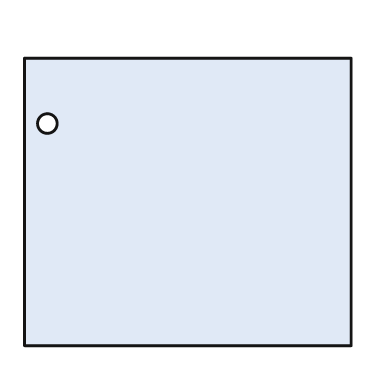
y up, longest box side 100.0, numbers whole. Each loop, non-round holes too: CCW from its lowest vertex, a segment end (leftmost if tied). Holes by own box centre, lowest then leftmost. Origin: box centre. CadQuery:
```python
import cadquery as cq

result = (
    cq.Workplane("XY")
    .moveTo(-50.0, -44.0)
    .lineTo(50.0, -44.0)
    .lineTo(50.0, 44.0)
    .lineTo(-50.0, 44.0)
    .close()
    .moveTo(-43.0, 24.0)
    .circle(3.0)
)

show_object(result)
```